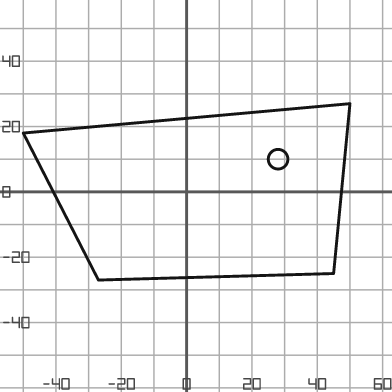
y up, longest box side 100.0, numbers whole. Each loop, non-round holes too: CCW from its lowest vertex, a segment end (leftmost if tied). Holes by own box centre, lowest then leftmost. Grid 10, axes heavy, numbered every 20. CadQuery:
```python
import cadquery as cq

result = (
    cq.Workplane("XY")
    .moveTo(-27.0, -27.0)
    .lineTo(45.0, -25.0)
    .lineTo(50.0, 27.0)
    .lineTo(-50.0, 18.0)
    .close()
    .moveTo(28.0, 10.0)
    .circle(3.0)
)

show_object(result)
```